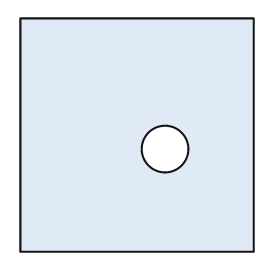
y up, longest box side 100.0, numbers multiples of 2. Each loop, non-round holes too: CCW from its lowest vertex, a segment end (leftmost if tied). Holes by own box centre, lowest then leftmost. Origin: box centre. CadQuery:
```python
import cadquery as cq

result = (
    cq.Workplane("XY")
    .moveTo(-50.0, -50.0)
    .lineTo(50.0, -50.0)
    .lineTo(50.0, 50.0)
    .lineTo(-50.0, 50.0)
    .close()
    .moveTo(12.0, -6.0)
    .circle(10.0)
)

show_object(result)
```